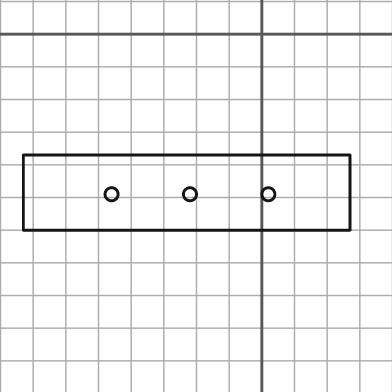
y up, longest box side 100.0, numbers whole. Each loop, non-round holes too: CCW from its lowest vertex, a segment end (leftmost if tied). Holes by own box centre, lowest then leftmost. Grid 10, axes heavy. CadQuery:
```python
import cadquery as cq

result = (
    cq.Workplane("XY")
    .moveTo(-73.0, -60.0)
    .lineTo(27.0, -60.0)
    .lineTo(27.0, -37.0)
    .lineTo(-73.0, -37.0)
    .close()
    .moveTo(-46.0, -49.0)
    .circle(2.0)
    .moveTo(-22.0, -49.0)
    .circle(2.0)
    .moveTo(2.0, -49.0)
    .circle(2.0)
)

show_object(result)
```